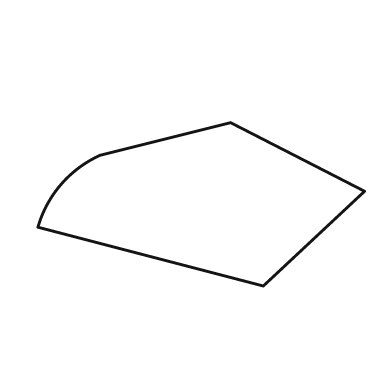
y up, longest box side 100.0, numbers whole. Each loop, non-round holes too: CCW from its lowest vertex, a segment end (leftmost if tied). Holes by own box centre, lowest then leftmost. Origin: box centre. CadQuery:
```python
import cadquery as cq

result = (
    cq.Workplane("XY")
    .moveTo(19.0, -25.0)
    .lineTo(50.0, 4.0)
    .lineTo(9.0, 25.0)
    .lineTo(-31.0, 15.0)
    .threePointArc((-43.0, 6.0), (-50.0, -7.0))
    .close()
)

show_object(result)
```